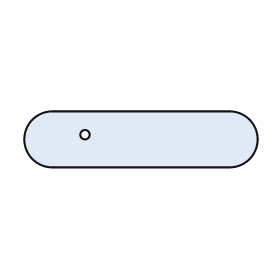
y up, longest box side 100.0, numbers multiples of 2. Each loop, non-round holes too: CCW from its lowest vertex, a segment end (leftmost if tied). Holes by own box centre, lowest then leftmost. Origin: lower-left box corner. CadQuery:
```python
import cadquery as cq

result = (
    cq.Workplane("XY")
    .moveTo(12.0, 0.0)
    .lineTo(88.0, 0.0)
    .threePointArc((100.0, 12.0), (88.0, 24.0))
    .lineTo(12.0, 24.0)
    .threePointArc((0.0, 12.0), (12.0, 0.0))
    .close()
    .moveTo(26.0, 14.0)
    .circle(2.0)
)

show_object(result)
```